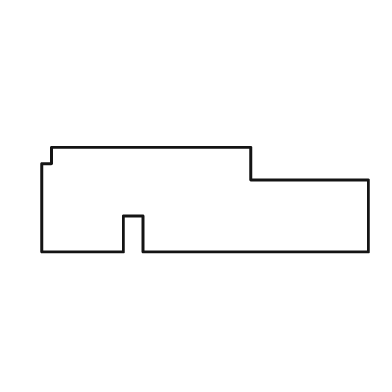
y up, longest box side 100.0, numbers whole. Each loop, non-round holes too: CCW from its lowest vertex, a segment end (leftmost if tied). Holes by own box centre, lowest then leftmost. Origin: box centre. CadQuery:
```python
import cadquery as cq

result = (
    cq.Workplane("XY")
    .moveTo(-50.0, -16.0)
    .lineTo(-25.0, -16.0)
    .lineTo(-25.0, -5.0)
    .lineTo(-19.0, -5.0)
    .lineTo(-19.0, -16.0)
    .lineTo(50.0, -16.0)
    .lineTo(50.0, 6.0)
    .lineTo(14.0, 6.0)
    .lineTo(14.0, 16.0)
    .lineTo(-47.0, 16.0)
    .lineTo(-47.0, 11.0)
    .lineTo(-50.0, 11.0)
    .close()
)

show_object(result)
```